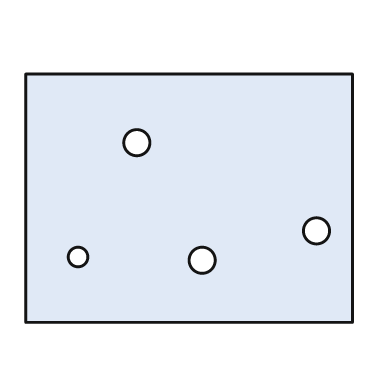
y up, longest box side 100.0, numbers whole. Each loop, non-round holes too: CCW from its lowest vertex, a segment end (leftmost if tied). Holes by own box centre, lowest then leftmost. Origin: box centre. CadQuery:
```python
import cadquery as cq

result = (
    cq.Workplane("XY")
    .moveTo(-50.0, -38.0)
    .lineTo(50.0, -38.0)
    .lineTo(50.0, 38.0)
    .lineTo(-50.0, 38.0)
    .close()
    .moveTo(4.0, -19.0)
    .circle(4.0)
    .moveTo(-34.0, -18.0)
    .circle(3.0)
    .moveTo(39.0, -10.0)
    .circle(4.0)
    .moveTo(-16.0, 17.0)
    .circle(4.0)
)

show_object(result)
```